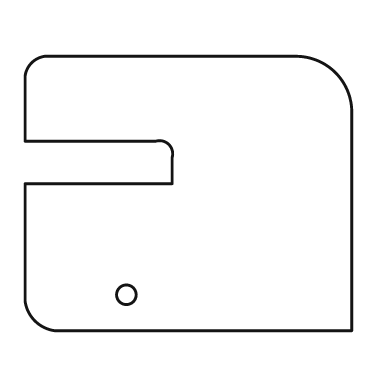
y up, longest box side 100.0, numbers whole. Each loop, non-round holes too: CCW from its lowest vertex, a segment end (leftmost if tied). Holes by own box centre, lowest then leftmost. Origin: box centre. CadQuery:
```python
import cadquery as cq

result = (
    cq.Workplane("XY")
    .moveTo(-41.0, -42.0)
    .lineTo(50.0, -42.0)
    .lineTo(50.0, 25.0)
    .threePointArc((45.0, 37.0), (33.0, 42.0))
    .lineTo(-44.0, 42.0)
    .threePointArc((-48.0, 40.0), (-50.0, 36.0))
    .lineTo(-50.0, 16.0)
    .lineTo(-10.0, 16.0)
    .threePointArc((-6.0, 15.0), (-5.0, 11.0))
    .lineTo(-5.0, 3.0)
    .lineTo(-50.0, 3.0)
    .lineTo(-50.0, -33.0)
    .threePointArc((-47.0, -39.0), (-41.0, -42.0))
    .close()
    .moveTo(-19.0, -31.0)
    .circle(3.0)
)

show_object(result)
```